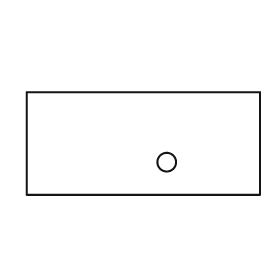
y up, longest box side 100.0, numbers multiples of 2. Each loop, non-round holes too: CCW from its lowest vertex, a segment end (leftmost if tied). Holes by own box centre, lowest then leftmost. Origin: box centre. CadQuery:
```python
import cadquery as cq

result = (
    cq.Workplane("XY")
    .moveTo(-50.0, -22.0)
    .lineTo(50.0, -22.0)
    .lineTo(50.0, 22.0)
    .lineTo(-50.0, 22.0)
    .close()
    .moveTo(10.0, -8.0)
    .circle(4.0)
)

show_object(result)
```